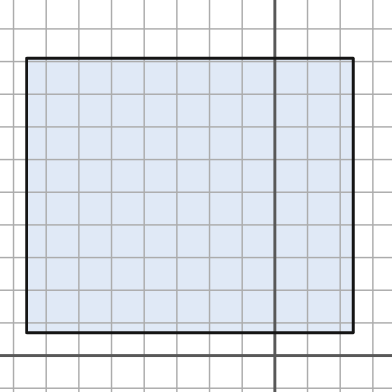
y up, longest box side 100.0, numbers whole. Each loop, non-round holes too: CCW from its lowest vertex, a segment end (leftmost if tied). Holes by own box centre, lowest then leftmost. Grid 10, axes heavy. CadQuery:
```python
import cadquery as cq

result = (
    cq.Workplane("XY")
    .moveTo(-76.0, 7.0)
    .lineTo(24.0, 7.0)
    .lineTo(24.0, 91.0)
    .lineTo(-76.0, 91.0)
    .close()
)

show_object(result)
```